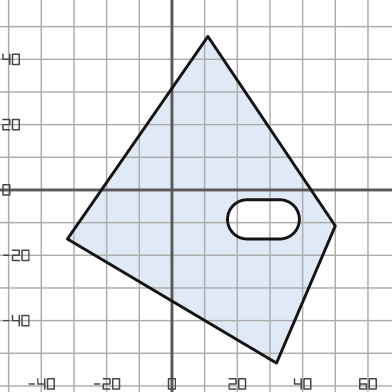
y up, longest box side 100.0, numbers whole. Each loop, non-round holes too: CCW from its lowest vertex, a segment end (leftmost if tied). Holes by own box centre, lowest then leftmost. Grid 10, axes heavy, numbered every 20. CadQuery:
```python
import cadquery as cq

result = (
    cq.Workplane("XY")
    .moveTo(32.0, -53.0)
    .lineTo(50.0, -11.0)
    .lineTo(11.0, 47.0)
    .lineTo(-32.0, -15.0)
    .close()
    .moveTo(23.0, -15.0)
    .lineTo(33.0, -15.0)
    .threePointArc((39.0, -9.0), (33.0, -3.0))
    .lineTo(23.0, -3.0)
    .threePointArc((17.0, -9.0), (23.0, -15.0))
    .close()
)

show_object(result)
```